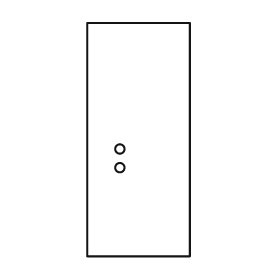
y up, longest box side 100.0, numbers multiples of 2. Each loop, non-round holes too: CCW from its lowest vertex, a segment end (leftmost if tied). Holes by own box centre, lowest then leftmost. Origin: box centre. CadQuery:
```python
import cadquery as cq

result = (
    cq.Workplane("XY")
    .moveTo(-22.0, -50.0)
    .lineTo(22.0, -50.0)
    .lineTo(22.0, 50.0)
    .lineTo(-22.0, 50.0)
    .close()
    .moveTo(-8.0, -12.0)
    .circle(2.0)
    .moveTo(-8.0, -4.0)
    .circle(2.0)
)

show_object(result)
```